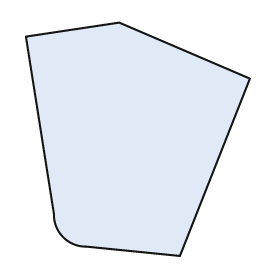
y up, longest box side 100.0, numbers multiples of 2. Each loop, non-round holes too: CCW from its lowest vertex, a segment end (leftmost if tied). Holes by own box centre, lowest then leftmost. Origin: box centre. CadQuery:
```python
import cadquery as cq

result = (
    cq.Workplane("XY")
    .moveTo(18.0, -50.0)
    .lineTo(48.0, 26.0)
    .lineTo(-8.0, 50.0)
    .lineTo(-48.0, 44.0)
    .lineTo(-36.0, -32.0)
    .threePointArc((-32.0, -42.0), (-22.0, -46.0))
    .close()
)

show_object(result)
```